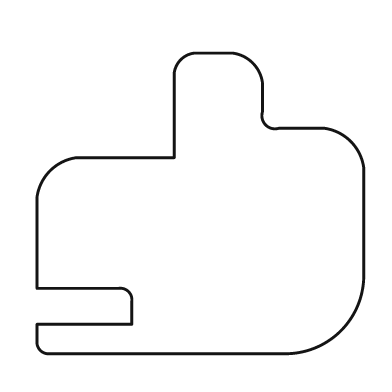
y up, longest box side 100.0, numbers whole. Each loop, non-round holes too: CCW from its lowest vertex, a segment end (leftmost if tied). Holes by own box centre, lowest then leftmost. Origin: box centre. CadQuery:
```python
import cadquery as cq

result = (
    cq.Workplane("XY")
    .moveTo(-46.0, -46.0)
    .lineTo(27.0, -46.0)
    .threePointArc((43.0, -39.0), (50.0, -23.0))
    .lineTo(50.0, 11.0)
    .threePointArc((46.0, 19.0), (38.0, 23.0))
    .lineTo(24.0, 23.0)
    .threePointArc((20.0, 24.0), (19.0, 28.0))
    .lineTo(19.0, 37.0)
    .threePointArc((16.0, 43.0), (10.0, 46.0))
    .lineTo(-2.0, 46.0)
    .threePointArc((-6.0, 44.0), (-8.0, 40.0))
    .lineTo(-8.0, 14.0)
    .lineTo(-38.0, 14.0)
    .threePointArc((-46.0, 10.0), (-50.0, 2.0))
    .lineTo(-50.0, -26.0)
    .lineTo(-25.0, -26.0)
    .threePointArc((-22.0, -27.0), (-21.0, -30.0))
    .lineTo(-21.0, -37.0)
    .lineTo(-50.0, -37.0)
    .lineTo(-50.0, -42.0)
    .threePointArc((-49.0, -45.0), (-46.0, -46.0))
    .close()
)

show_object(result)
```